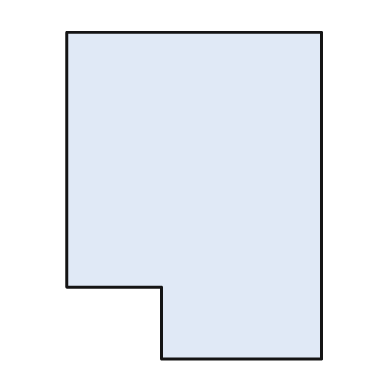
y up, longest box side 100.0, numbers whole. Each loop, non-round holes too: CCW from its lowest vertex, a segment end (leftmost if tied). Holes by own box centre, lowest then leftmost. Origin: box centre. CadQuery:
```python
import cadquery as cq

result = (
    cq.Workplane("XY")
    .moveTo(-10.0, -50.0)
    .lineTo(39.0, -50.0)
    .lineTo(39.0, 50.0)
    .lineTo(-39.0, 50.0)
    .lineTo(-39.0, -28.0)
    .lineTo(-10.0, -28.0)
    .close()
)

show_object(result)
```